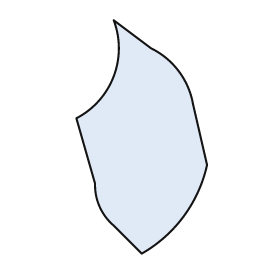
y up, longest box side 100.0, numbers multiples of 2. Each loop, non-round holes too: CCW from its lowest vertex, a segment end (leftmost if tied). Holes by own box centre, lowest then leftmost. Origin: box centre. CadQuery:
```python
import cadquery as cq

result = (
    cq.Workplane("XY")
    .moveTo(0.0, -50.0)
    .threePointArc((18.0, -34.0), (28.0, -12.0))
    .lineTo(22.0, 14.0)
    .threePointArc((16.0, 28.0), (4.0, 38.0))
    .lineTo(-12.0, 50.0)
    .threePointArc((-12.0, 26.0), (-28.0, 8.0))
    .lineTo(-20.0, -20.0)
    .threePointArc((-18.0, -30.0), (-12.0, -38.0))
    .close()
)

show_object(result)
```